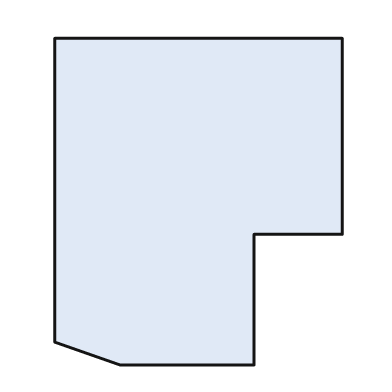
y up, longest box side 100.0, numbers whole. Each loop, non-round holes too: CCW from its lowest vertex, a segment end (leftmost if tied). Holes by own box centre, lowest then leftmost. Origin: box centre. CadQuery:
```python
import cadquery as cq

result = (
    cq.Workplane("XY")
    .moveTo(-24.0, -50.0)
    .lineTo(17.0, -50.0)
    .lineTo(17.0, -10.0)
    .lineTo(44.0, -10.0)
    .lineTo(44.0, 50.0)
    .lineTo(-44.0, 50.0)
    .lineTo(-44.0, -43.0)
    .close()
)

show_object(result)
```